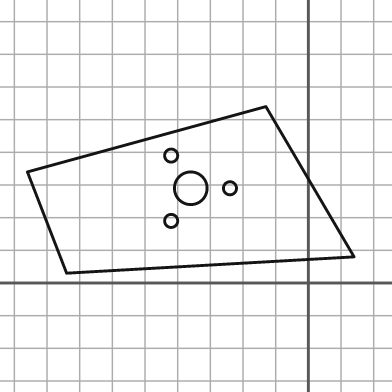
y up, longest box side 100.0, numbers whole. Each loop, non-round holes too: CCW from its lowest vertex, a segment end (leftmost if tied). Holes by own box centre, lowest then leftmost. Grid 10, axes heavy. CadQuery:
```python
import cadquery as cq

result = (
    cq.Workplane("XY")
    .moveTo(-74.0, 3.0)
    .lineTo(14.0, 8.0)
    .lineTo(-13.0, 54.0)
    .lineTo(-86.0, 34.0)
    .close()
    .moveTo(-42.0, 19.0)
    .circle(2.0)
    .moveTo(-36.0, 29.0)
    .circle(5.0)
    .moveTo(-24.0, 29.0)
    .circle(2.0)
    .moveTo(-42.0, 39.0)
    .circle(2.0)
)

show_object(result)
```